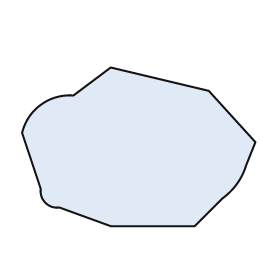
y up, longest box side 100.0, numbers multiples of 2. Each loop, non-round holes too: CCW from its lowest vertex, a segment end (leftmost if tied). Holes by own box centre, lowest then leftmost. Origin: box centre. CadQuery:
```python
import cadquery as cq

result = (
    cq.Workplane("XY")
    .moveTo(-12.0, -34.0)
    .lineTo(24.0, -34.0)
    .lineTo(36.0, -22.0)
    .threePointArc((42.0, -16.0), (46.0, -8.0))
    .lineTo(50.0, 2.0)
    .lineTo(30.0, 24.0)
    .lineTo(-12.0, 34.0)
    .lineTo(-28.0, 22.0)
    .threePointArc((-42.0, 18.0), (-50.0, 6.0))
    .lineTo(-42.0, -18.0)
    .threePointArc((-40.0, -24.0), (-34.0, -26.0))
    .close()
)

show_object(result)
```